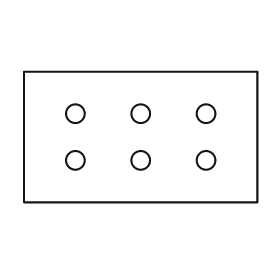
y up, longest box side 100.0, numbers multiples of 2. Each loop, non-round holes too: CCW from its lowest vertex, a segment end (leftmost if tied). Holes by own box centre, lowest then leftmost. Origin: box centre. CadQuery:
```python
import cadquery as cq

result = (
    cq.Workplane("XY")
    .moveTo(-50.0, -28.0)
    .lineTo(50.0, -28.0)
    .lineTo(50.0, 28.0)
    .lineTo(-50.0, 28.0)
    .close()
    .moveTo(-28.0, -10.0)
    .circle(4.0)
    .moveTo(0.0, -10.0)
    .circle(4.0)
    .moveTo(28.0, -10.0)
    .circle(4.0)
    .moveTo(-28.0, 10.0)
    .circle(4.0)
    .moveTo(0.0, 10.0)
    .circle(4.0)
    .moveTo(28.0, 10.0)
    .circle(4.0)
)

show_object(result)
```